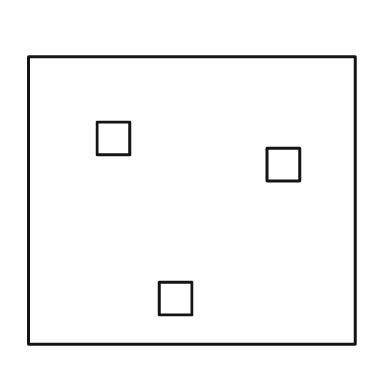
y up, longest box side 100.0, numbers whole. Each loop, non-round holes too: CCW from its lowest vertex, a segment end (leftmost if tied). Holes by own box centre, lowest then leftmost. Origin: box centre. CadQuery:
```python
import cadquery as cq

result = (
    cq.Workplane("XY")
    .moveTo(-50.0, -44.0)
    .lineTo(50.0, -44.0)
    .lineTo(50.0, 44.0)
    .lineTo(-50.0, 44.0)
    .close()
    .moveTo(-10.0, -35.0)
    .lineTo(0.0, -35.0)
    .lineTo(0.0, -25.0)
    .lineTo(-10.0, -25.0)
    .close()
    .moveTo(23.0, 6.0)
    .lineTo(33.0, 6.0)
    .lineTo(33.0, 16.0)
    .lineTo(23.0, 16.0)
    .close()
    .moveTo(-29.0, 14.0)
    .lineTo(-19.0, 14.0)
    .lineTo(-19.0, 24.0)
    .lineTo(-29.0, 24.0)
    .close()
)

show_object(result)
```